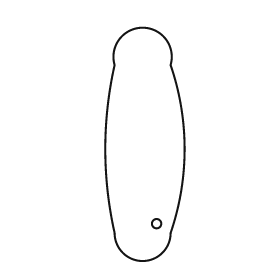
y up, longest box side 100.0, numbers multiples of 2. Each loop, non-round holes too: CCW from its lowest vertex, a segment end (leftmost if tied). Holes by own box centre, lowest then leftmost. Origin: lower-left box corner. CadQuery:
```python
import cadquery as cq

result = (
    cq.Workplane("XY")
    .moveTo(4.0, 12.0)
    .threePointArc((16.0, 0.0), (28.0, 12.0))
    .threePointArc((34.0, 48.0), (28.0, 84.0))
    .threePointArc((16.0, 100.0), (4.0, 84.0))
    .threePointArc((0.0, 48.0), (4.0, 12.0))
    .close()
    .moveTo(22.0, 16.0)
    .circle(2.0)
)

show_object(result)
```